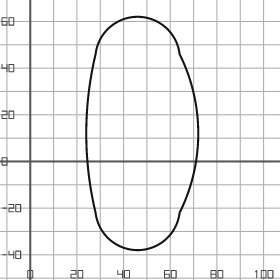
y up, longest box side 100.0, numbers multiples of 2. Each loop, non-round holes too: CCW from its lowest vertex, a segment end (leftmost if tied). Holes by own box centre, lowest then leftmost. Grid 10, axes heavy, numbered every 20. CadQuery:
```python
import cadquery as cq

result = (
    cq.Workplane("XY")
    .moveTo(28.0, -22.0)
    .threePointArc((46.0, -38.0), (64.0, -22.0))
    .threePointArc((72.0, 12.0), (64.0, 46.0))
    .threePointArc((46.0, 62.0), (28.0, 46.0))
    .threePointArc((24.0, 12.0), (28.0, -22.0))
    .close()
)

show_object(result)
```